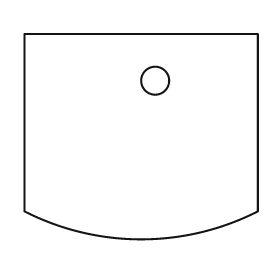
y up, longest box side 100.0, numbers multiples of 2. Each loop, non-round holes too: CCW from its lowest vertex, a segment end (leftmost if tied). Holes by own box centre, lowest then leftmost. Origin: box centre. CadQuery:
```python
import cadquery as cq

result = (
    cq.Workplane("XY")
    .moveTo(-50.0, -32.0)
    .threePointArc((0.0, -44.0), (50.0, -32.0))
    .lineTo(50.0, 44.0)
    .lineTo(-50.0, 44.0)
    .close()
    .moveTo(6.0, 24.0)
    .circle(6.0)
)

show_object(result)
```